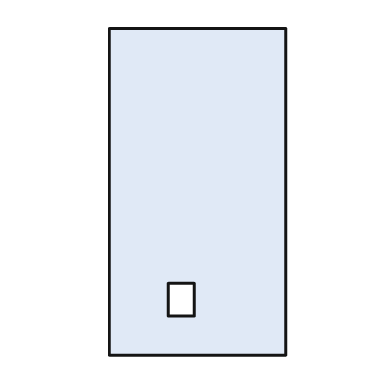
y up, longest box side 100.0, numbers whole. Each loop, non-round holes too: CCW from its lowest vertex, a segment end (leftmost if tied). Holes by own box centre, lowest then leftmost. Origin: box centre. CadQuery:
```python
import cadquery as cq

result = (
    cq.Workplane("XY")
    .moveTo(-27.0, -50.0)
    .lineTo(27.0, -50.0)
    .lineTo(27.0, 50.0)
    .lineTo(-27.0, 50.0)
    .close()
    .moveTo(-9.0, -38.0)
    .lineTo(-1.0, -38.0)
    .lineTo(-1.0, -28.0)
    .lineTo(-9.0, -28.0)
    .close()
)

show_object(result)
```